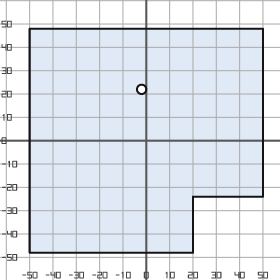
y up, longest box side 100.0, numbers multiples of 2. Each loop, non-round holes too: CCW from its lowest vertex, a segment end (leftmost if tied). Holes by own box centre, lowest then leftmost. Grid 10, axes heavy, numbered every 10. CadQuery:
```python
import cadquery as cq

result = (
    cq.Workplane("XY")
    .moveTo(-50.0, -48.0)
    .lineTo(20.0, -48.0)
    .lineTo(20.0, -24.0)
    .lineTo(50.0, -24.0)
    .lineTo(50.0, 48.0)
    .lineTo(-50.0, 48.0)
    .close()
    .moveTo(-2.0, 22.0)
    .circle(2.0)
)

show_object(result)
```